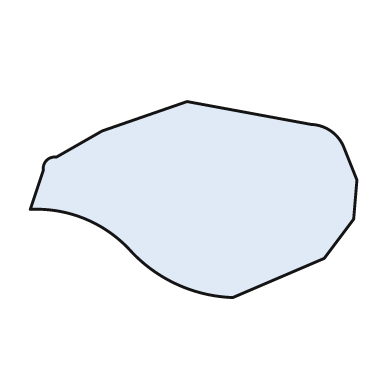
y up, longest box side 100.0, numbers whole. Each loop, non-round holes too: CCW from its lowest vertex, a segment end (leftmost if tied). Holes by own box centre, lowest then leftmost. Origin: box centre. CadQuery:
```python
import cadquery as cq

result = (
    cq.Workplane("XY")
    .moveTo(12.0, -30.0)
    .lineTo(40.0, -18.0)
    .lineTo(49.0, -6.0)
    .lineTo(50.0, 6.0)
    .lineTo(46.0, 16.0)
    .threePointArc((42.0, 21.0), (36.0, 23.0))
    .lineTo(-2.0, 30.0)
    .lineTo(-28.0, 21.0)
    .lineTo(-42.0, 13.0)
    .threePointArc((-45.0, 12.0), (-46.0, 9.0))
    .lineTo(-50.0, -3.0)
    .threePointArc((-33.0, -6.0), (-19.0, -16.0))
    .threePointArc((-5.0, -26.0), (12.0, -30.0))
    .close()
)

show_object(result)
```